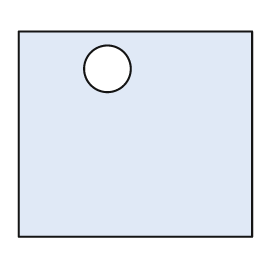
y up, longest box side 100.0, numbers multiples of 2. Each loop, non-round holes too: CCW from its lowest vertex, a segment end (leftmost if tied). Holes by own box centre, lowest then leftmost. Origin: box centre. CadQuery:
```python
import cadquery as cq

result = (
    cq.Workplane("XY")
    .moveTo(-50.0, -44.0)
    .lineTo(50.0, -44.0)
    .lineTo(50.0, 44.0)
    .lineTo(-50.0, 44.0)
    .close()
    .moveTo(-12.0, 28.0)
    .circle(10.0)
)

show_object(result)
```